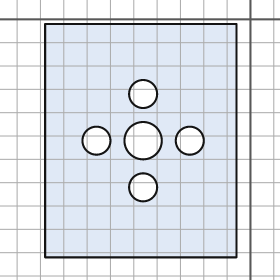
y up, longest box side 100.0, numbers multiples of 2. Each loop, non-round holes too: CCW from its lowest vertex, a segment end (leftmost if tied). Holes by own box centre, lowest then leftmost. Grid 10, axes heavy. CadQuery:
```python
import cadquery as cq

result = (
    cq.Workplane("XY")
    .moveTo(-88.0, -102.0)
    .lineTo(-6.0, -102.0)
    .lineTo(-6.0, -2.0)
    .lineTo(-88.0, -2.0)
    .close()
    .moveTo(-46.0, -72.0)
    .circle(6.0)
    .moveTo(-66.0, -52.0)
    .circle(6.0)
    .moveTo(-46.0, -52.0)
    .circle(8.0)
    .moveTo(-26.0, -52.0)
    .circle(6.0)
    .moveTo(-46.0, -32.0)
    .circle(6.0)
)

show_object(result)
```